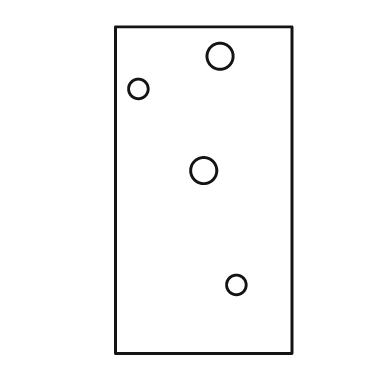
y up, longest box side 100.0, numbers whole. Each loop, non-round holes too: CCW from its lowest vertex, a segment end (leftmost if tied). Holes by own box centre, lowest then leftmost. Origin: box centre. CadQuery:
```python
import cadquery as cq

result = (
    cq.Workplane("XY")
    .moveTo(-27.0, -50.0)
    .lineTo(27.0, -50.0)
    .lineTo(27.0, 50.0)
    .lineTo(-27.0, 50.0)
    .close()
    .moveTo(10.0, -29.0)
    .circle(3.0)
    .moveTo(0.0, 6.0)
    .circle(4.0)
    .moveTo(-20.0, 31.0)
    .circle(3.0)
    .moveTo(5.0, 41.0)
    .circle(4.0)
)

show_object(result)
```